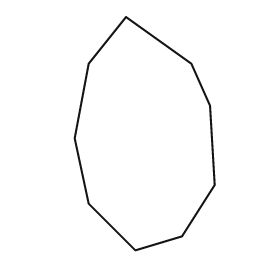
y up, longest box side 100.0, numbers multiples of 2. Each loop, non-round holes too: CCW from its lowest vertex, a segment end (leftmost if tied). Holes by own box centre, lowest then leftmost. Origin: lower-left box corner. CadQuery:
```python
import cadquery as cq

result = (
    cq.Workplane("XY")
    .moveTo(26.0, 0.0)
    .lineTo(46.0, 6.0)
    .lineTo(60.0, 28.0)
    .lineTo(58.0, 62.0)
    .lineTo(50.0, 80.0)
    .lineTo(22.0, 100.0)
    .lineTo(6.0, 80.0)
    .lineTo(0.0, 48.0)
    .lineTo(6.0, 20.0)
    .close()
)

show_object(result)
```